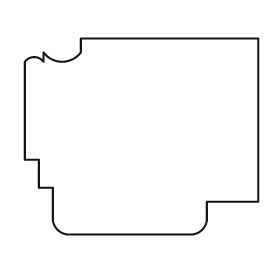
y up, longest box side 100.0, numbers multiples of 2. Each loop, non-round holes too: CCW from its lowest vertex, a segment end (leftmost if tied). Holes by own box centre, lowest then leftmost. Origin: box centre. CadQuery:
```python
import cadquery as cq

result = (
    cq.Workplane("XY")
    .moveTo(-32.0, -42.0)
    .lineTo(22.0, -42.0)
    .threePointArc((26.0, -40.0), (28.0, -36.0))
    .lineTo(28.0, -28.0)
    .lineTo(50.0, -28.0)
    .lineTo(50.0, 42.0)
    .lineTo(-26.0, 42.0)
    .lineTo(-26.0, 36.0)
    .threePointArc((-34.0, 32.0), (-42.0, 36.0))
    .lineTo(-42.0, 32.0)
    .threePointArc((-46.0, 34.0), (-50.0, 32.0))
    .lineTo(-50.0, -10.0)
    .lineTo(-44.0, -10.0)
    .lineTo(-44.0, -22.0)
    .lineTo(-38.0, -22.0)
    .lineTo(-38.0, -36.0)
    .threePointArc((-36.0, -40.0), (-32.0, -42.0))
    .close()
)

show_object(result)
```